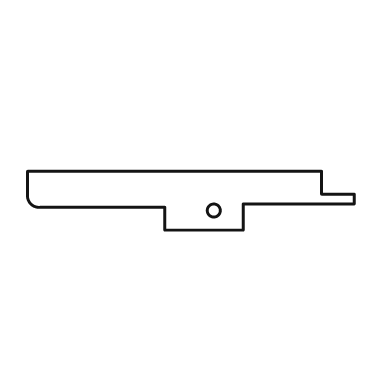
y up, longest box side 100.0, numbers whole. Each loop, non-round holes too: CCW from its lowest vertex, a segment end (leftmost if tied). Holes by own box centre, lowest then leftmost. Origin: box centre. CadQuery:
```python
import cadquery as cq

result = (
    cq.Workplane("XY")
    .moveTo(-8.0, -9.0)
    .lineTo(16.0, -9.0)
    .lineTo(16.0, -1.0)
    .lineTo(50.0, -1.0)
    .lineTo(50.0, 2.0)
    .lineTo(40.0, 2.0)
    .lineTo(40.0, 9.0)
    .lineTo(-50.0, 9.0)
    .lineTo(-50.0, 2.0)
    .threePointArc((-49.0, -1.0), (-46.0, -2.0))
    .lineTo(-8.0, -2.0)
    .close()
    .moveTo(7.0, -3.0)
    .circle(2.0)
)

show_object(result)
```